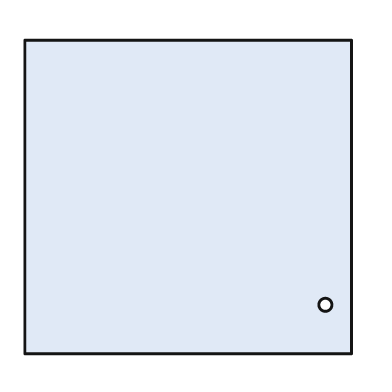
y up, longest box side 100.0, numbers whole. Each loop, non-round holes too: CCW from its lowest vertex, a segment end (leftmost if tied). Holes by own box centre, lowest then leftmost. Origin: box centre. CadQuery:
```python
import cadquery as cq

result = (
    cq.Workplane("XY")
    .moveTo(-50.0, -48.0)
    .lineTo(50.0, -48.0)
    .lineTo(50.0, 48.0)
    .lineTo(-50.0, 48.0)
    .close()
    .moveTo(42.0, -33.0)
    .circle(2.0)
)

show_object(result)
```